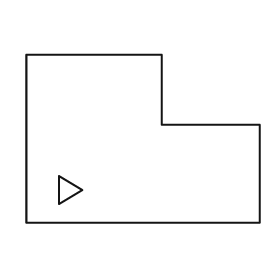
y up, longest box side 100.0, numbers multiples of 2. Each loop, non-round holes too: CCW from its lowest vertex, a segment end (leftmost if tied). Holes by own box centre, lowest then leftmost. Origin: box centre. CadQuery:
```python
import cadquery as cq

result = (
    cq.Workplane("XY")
    .moveTo(-50.0, -36.0)
    .lineTo(50.0, -36.0)
    .lineTo(50.0, 6.0)
    .lineTo(8.0, 6.0)
    .lineTo(8.0, 36.0)
    .lineTo(-50.0, 36.0)
    .close()
    .moveTo(-36.0, -28.0)
    .lineTo(-26.0, -22.0)
    .lineTo(-36.0, -16.0)
    .close()
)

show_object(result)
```